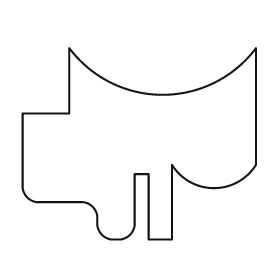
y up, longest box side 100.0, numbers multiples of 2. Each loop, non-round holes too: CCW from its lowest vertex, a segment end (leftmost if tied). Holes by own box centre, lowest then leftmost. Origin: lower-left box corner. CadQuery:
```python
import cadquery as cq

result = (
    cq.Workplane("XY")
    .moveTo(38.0, 0.0)
    .lineTo(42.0, 0.0)
    .threePointArc((46.0, 2.0), (48.0, 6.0))
    .lineTo(48.0, 28.0)
    .lineTo(54.0, 28.0)
    .lineTo(54.0, 0.0)
    .lineTo(64.0, 0.0)
    .lineTo(64.0, 32.0)
    .threePointArc((82.0, 22.0), (100.0, 32.0))
    .lineTo(100.0, 82.0)
    .threePointArc((60.0, 62.0), (20.0, 82.0))
    .lineTo(20.0, 54.0)
    .lineTo(0.0, 54.0)
    .lineTo(0.0, 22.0)
    .threePointArc((2.0, 18.0), (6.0, 16.0))
    .lineTo(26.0, 16.0)
    .threePointArc((30.0, 14.0), (32.0, 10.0))
    .lineTo(32.0, 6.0)
    .threePointArc((34.0, 2.0), (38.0, 0.0))
    .close()
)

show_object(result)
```